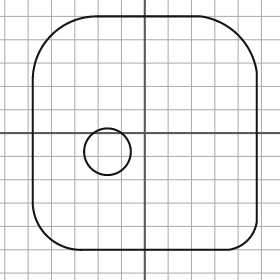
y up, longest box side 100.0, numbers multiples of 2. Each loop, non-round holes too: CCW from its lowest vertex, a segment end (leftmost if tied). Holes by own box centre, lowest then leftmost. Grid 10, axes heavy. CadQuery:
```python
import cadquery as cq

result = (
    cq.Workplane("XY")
    .moveTo(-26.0, -50.0)
    .lineTo(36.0, -50.0)
    .threePointArc((44.0, -46.0), (48.0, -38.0))
    .lineTo(48.0, 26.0)
    .threePointArc((40.0, 42.0), (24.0, 50.0))
    .lineTo(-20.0, 50.0)
    .threePointArc((-40.0, 42.0), (-48.0, 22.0))
    .lineTo(-48.0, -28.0)
    .threePointArc((-42.0, -44.0), (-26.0, -50.0))
    .close()
    .moveTo(-16.0, -8.0)
    .circle(10.0)
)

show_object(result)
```